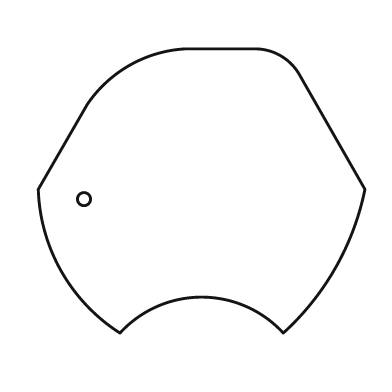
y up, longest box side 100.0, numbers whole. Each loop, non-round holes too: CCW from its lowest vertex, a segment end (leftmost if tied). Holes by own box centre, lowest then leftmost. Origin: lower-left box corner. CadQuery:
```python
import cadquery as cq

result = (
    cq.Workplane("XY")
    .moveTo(25.0, 0.0)
    .threePointArc((50.0, 11.0), (75.0, 0.0))
    .threePointArc((91.0, 20.0), (100.0, 44.0))
    .lineTo(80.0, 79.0)
    .threePointArc((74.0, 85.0), (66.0, 87.0))
    .lineTo(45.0, 87.0)
    .threePointArc((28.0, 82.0), (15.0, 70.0))
    .lineTo(0.0, 44.0)
    .threePointArc((7.0, 19.0), (25.0, 0.0))
    .close()
    .moveTo(14.0, 41.0)
    .circle(2.0)
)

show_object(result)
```